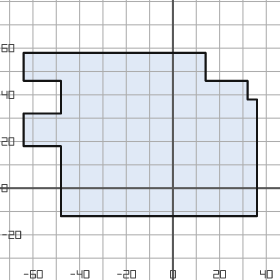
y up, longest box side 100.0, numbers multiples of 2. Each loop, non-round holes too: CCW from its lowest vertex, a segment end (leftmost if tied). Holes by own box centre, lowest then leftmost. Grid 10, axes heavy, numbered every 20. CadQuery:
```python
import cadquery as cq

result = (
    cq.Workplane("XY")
    .moveTo(-48.0, -12.0)
    .lineTo(36.0, -12.0)
    .lineTo(36.0, 38.0)
    .lineTo(32.0, 38.0)
    .lineTo(32.0, 46.0)
    .lineTo(14.0, 46.0)
    .lineTo(14.0, 58.0)
    .lineTo(-64.0, 58.0)
    .lineTo(-64.0, 46.0)
    .lineTo(-48.0, 46.0)
    .lineTo(-48.0, 32.0)
    .lineTo(-64.0, 32.0)
    .lineTo(-64.0, 18.0)
    .lineTo(-48.0, 18.0)
    .close()
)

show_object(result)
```